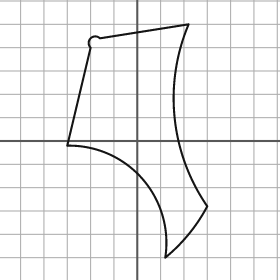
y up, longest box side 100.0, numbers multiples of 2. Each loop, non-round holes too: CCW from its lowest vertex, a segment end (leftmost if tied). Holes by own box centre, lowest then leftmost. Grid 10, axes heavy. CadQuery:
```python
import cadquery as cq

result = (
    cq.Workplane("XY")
    .moveTo(12.0, -50.0)
    .threePointArc((22.0, -40.0), (30.0, -28.0))
    .threePointArc((16.0, 10.0), (22.0, 50.0))
    .lineTo(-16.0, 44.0)
    .threePointArc((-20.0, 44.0), (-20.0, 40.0))
    .lineTo(-30.0, -2.0)
    .threePointArc((2.0, -16.0), (12.0, -50.0))
    .close()
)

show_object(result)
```